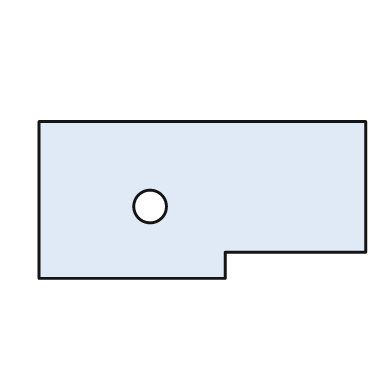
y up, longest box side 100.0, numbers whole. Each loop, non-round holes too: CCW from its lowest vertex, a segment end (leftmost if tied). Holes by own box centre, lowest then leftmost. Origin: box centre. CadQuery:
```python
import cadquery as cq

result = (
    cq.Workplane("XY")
    .moveTo(-50.0, -24.0)
    .lineTo(7.0, -24.0)
    .lineTo(7.0, -16.0)
    .lineTo(50.0, -16.0)
    .lineTo(50.0, 24.0)
    .lineTo(-50.0, 24.0)
    .close()
    .moveTo(-16.0, -2.0)
    .circle(5.0)
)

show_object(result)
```